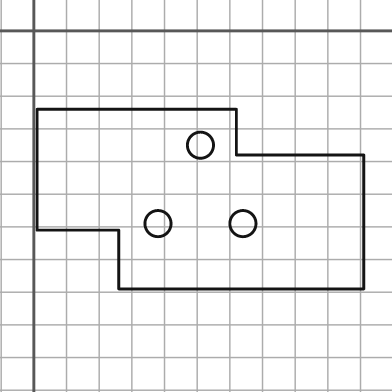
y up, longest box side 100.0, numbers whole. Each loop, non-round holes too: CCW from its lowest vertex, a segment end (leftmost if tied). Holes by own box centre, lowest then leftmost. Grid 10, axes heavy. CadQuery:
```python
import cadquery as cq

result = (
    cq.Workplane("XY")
    .moveTo(26.0, -79.0)
    .lineTo(101.0, -79.0)
    .lineTo(101.0, -38.0)
    .lineTo(62.0, -38.0)
    .lineTo(62.0, -24.0)
    .lineTo(1.0, -24.0)
    .lineTo(1.0, -61.0)
    .lineTo(26.0, -61.0)
    .close()
    .moveTo(38.0, -59.0)
    .circle(4.0)
    .moveTo(64.0, -59.0)
    .circle(4.0)
    .moveTo(51.0, -35.0)
    .circle(4.0)
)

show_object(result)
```